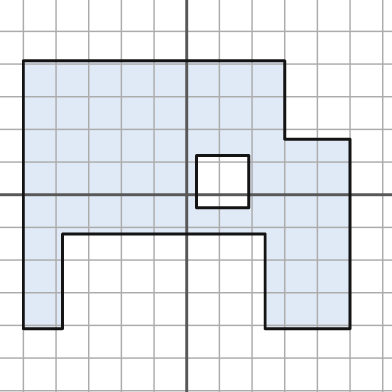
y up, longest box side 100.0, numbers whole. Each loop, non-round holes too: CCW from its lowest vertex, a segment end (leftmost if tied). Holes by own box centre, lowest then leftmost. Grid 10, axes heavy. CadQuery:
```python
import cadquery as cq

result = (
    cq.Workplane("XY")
    .moveTo(-50.0, -41.0)
    .lineTo(-38.0, -41.0)
    .lineTo(-38.0, -12.0)
    .lineTo(24.0, -12.0)
    .lineTo(24.0, -41.0)
    .lineTo(50.0, -41.0)
    .lineTo(50.0, 17.0)
    .lineTo(30.0, 17.0)
    .lineTo(30.0, 41.0)
    .lineTo(-50.0, 41.0)
    .close()
    .moveTo(3.0, -4.0)
    .lineTo(19.0, -4.0)
    .lineTo(19.0, 12.0)
    .lineTo(3.0, 12.0)
    .close()
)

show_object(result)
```